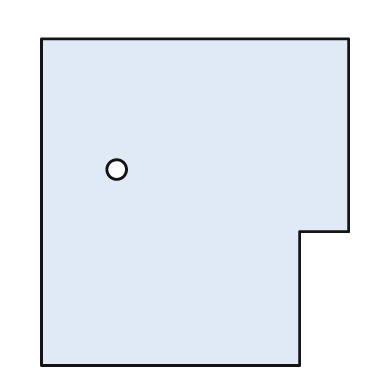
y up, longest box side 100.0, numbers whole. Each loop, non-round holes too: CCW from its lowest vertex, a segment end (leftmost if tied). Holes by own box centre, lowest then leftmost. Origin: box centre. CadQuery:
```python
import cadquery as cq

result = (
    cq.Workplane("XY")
    .moveTo(-47.0, -50.0)
    .lineTo(32.0, -50.0)
    .lineTo(32.0, -9.0)
    .lineTo(47.0, -9.0)
    .lineTo(47.0, 50.0)
    .lineTo(-47.0, 50.0)
    .close()
    .moveTo(-24.0, 10.0)
    .circle(3.0)
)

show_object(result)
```